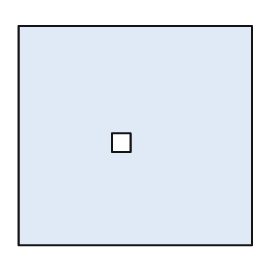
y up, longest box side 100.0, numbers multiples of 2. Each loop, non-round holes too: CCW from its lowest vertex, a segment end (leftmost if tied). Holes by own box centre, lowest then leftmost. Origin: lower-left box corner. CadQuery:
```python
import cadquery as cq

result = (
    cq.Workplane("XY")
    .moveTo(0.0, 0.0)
    .lineTo(100.0, 0.0)
    .lineTo(100.0, 94.0)
    .lineTo(0.0, 94.0)
    .close()
    .moveTo(40.0, 40.0)
    .lineTo(48.0, 40.0)
    .lineTo(48.0, 48.0)
    .lineTo(40.0, 48.0)
    .close()
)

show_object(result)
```